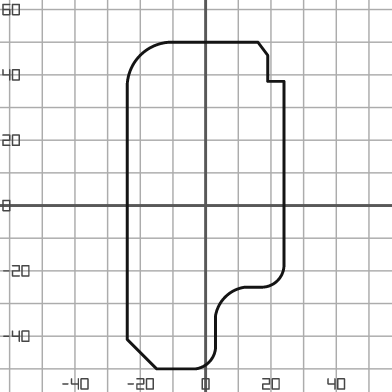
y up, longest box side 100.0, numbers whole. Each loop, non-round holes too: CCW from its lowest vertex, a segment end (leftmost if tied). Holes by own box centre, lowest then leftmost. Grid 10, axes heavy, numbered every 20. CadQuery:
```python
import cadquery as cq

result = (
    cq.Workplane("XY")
    .moveTo(-15.0, -50.0)
    .lineTo(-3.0, -50.0)
    .threePointArc((1.0, -48.0), (3.0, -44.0))
    .lineTo(3.0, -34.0)
    .threePointArc((6.0, -28.0), (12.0, -25.0))
    .lineTo(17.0, -25.0)
    .threePointArc((22.0, -23.0), (24.0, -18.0))
    .lineTo(24.0, 38.0)
    .lineTo(19.0, 38.0)
    .lineTo(19.0, 46.0)
    .lineTo(16.0, 50.0)
    .lineTo(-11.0, 50.0)
    .threePointArc((-20.0, 46.0), (-24.0, 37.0))
    .lineTo(-24.0, -41.0)
    .close()
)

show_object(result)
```